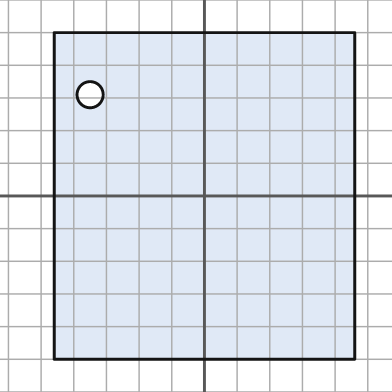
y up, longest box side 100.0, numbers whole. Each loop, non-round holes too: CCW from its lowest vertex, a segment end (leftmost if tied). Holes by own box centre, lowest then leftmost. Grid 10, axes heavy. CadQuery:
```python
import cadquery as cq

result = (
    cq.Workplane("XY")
    .moveTo(-46.0, -50.0)
    .lineTo(46.0, -50.0)
    .lineTo(46.0, 50.0)
    .lineTo(-46.0, 50.0)
    .close()
    .moveTo(-35.0, 31.0)
    .circle(4.0)
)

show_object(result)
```